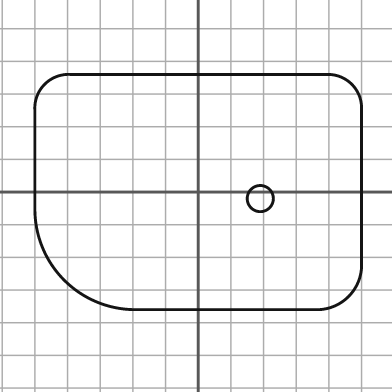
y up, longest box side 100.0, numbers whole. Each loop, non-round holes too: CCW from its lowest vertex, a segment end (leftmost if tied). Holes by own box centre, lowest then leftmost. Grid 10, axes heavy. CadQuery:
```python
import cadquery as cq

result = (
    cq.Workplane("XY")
    .moveTo(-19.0, -36.0)
    .lineTo(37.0, -36.0)
    .threePointArc((46.0, -32.0), (50.0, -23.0))
    .lineTo(50.0, 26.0)
    .threePointArc((47.0, 33.0), (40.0, 36.0))
    .lineTo(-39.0, 36.0)
    .threePointArc((-47.0, 33.0), (-50.0, 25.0))
    .lineTo(-50.0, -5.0)
    .threePointArc((-41.0, -27.0), (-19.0, -36.0))
    .close()
    .moveTo(19.0, -2.0)
    .circle(4.0)
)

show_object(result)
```